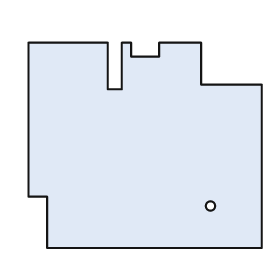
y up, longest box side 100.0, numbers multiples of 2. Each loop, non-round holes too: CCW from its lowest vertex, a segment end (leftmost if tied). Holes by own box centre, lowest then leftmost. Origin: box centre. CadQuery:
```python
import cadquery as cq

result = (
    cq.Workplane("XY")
    .moveTo(-42.0, -44.0)
    .lineTo(50.0, -44.0)
    .lineTo(50.0, 26.0)
    .lineTo(24.0, 26.0)
    .lineTo(24.0, 44.0)
    .lineTo(6.0, 44.0)
    .lineTo(6.0, 38.0)
    .lineTo(-6.0, 38.0)
    .lineTo(-6.0, 44.0)
    .lineTo(-10.0, 44.0)
    .lineTo(-10.0, 24.0)
    .lineTo(-16.0, 24.0)
    .lineTo(-16.0, 44.0)
    .lineTo(-50.0, 44.0)
    .lineTo(-50.0, -22.0)
    .lineTo(-42.0, -22.0)
    .close()
    .moveTo(28.0, -26.0)
    .circle(2.0)
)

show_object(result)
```